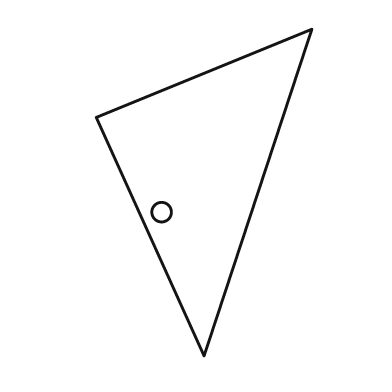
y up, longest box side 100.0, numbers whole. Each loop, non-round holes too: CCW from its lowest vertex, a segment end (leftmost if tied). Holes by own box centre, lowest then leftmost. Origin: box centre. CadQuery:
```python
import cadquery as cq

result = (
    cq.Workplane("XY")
    .moveTo(0.0, -50.0)
    .lineTo(33.0, 50.0)
    .lineTo(-33.0, 23.0)
    .close()
    .moveTo(-13.0, -6.0)
    .circle(3.0)
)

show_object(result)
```